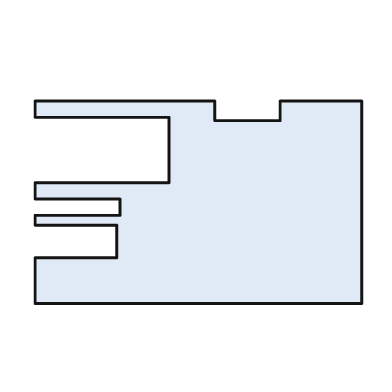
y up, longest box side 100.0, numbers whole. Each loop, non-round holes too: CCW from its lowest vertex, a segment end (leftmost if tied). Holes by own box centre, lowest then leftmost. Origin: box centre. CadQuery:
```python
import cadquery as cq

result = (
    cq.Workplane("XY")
    .moveTo(-50.0, -31.0)
    .lineTo(50.0, -31.0)
    .lineTo(50.0, 31.0)
    .lineTo(25.0, 31.0)
    .lineTo(25.0, 25.0)
    .lineTo(5.0, 25.0)
    .lineTo(5.0, 31.0)
    .lineTo(-50.0, 31.0)
    .lineTo(-50.0, 26.0)
    .lineTo(-9.0, 26.0)
    .lineTo(-9.0, 6.0)
    .lineTo(-50.0, 6.0)
    .lineTo(-50.0, 1.0)
    .lineTo(-24.0, 1.0)
    .lineTo(-24.0, -4.0)
    .lineTo(-50.0, -4.0)
    .lineTo(-50.0, -7.0)
    .lineTo(-25.0, -7.0)
    .lineTo(-25.0, -17.0)
    .lineTo(-50.0, -17.0)
    .close()
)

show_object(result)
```